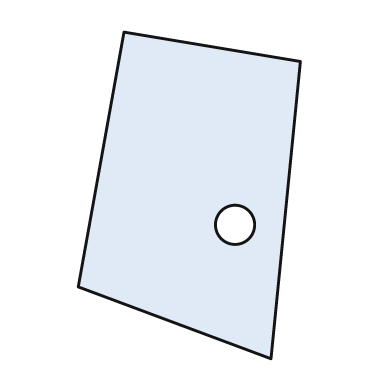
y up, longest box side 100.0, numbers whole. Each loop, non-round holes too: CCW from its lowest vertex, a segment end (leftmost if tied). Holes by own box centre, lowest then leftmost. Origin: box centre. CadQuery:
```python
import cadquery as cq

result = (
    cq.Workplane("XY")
    .moveTo(25.0, -50.0)
    .lineTo(34.0, 41.0)
    .lineTo(-20.0, 50.0)
    .lineTo(-34.0, -28.0)
    .close()
    .moveTo(14.0, -9.0)
    .circle(6.0)
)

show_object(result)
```